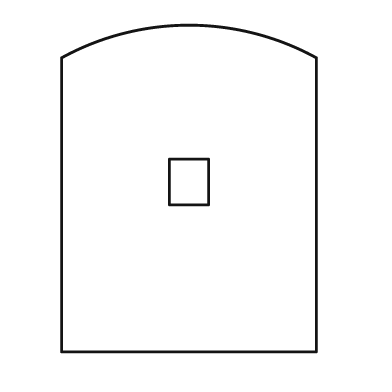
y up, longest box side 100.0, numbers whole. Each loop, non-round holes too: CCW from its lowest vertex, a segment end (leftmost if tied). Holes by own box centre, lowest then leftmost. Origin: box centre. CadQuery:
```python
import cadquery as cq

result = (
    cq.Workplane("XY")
    .moveTo(-39.0, -50.0)
    .lineTo(39.0, -50.0)
    .lineTo(39.0, 40.0)
    .threePointArc((0.0, 50.0), (-39.0, 40.0))
    .close()
    .moveTo(-6.0, -5.0)
    .lineTo(6.0, -5.0)
    .lineTo(6.0, 9.0)
    .lineTo(-6.0, 9.0)
    .close()
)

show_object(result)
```